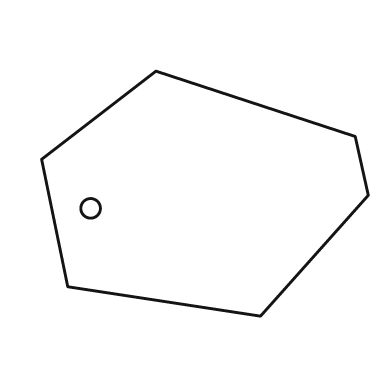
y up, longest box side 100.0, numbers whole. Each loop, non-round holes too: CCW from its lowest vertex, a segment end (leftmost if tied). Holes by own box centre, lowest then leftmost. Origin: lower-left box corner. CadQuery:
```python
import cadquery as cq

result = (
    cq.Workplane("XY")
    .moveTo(67.0, 0.0)
    .lineTo(100.0, 37.0)
    .lineTo(96.0, 55.0)
    .lineTo(35.0, 75.0)
    .lineTo(0.0, 48.0)
    .lineTo(8.0, 9.0)
    .close()
    .moveTo(15.0, 33.0)
    .circle(3.0)
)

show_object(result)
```